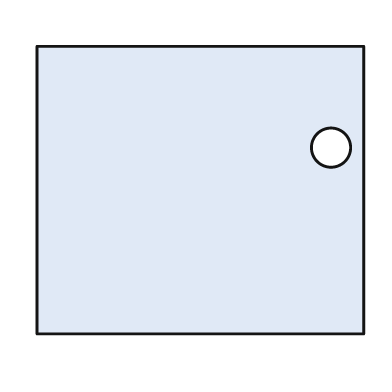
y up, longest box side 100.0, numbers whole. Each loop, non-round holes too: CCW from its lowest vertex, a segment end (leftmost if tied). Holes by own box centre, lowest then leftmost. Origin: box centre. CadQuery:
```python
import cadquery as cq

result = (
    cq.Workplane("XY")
    .moveTo(-50.0, -44.0)
    .lineTo(50.0, -44.0)
    .lineTo(50.0, 44.0)
    .lineTo(-50.0, 44.0)
    .close()
    .moveTo(40.0, 13.0)
    .circle(6.0)
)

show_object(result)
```